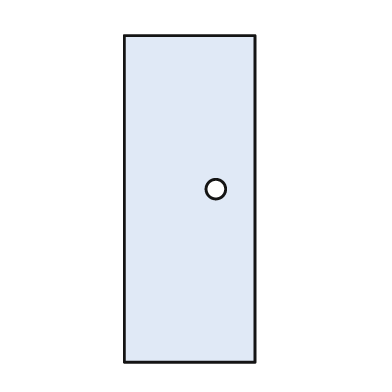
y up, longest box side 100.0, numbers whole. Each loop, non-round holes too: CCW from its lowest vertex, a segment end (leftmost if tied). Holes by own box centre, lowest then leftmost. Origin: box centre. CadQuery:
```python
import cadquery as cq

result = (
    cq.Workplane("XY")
    .moveTo(-20.0, -50.0)
    .lineTo(20.0, -50.0)
    .lineTo(20.0, 50.0)
    .lineTo(-20.0, 50.0)
    .close()
    .moveTo(8.0, 3.0)
    .circle(3.0)
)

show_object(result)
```